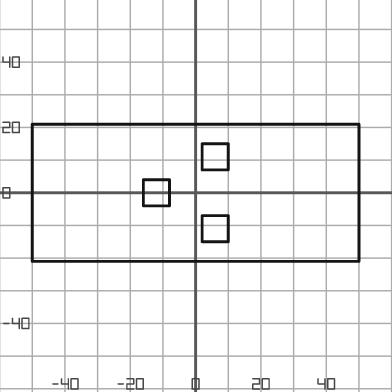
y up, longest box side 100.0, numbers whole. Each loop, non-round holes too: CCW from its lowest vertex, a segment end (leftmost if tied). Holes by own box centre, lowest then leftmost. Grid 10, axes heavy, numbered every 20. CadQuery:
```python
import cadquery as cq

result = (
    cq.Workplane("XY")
    .moveTo(-50.0, -21.0)
    .lineTo(50.0, -21.0)
    .lineTo(50.0, 21.0)
    .lineTo(-50.0, 21.0)
    .close()
    .moveTo(2.0, -15.0)
    .lineTo(10.0, -15.0)
    .lineTo(10.0, -7.0)
    .lineTo(2.0, -7.0)
    .close()
    .moveTo(-16.0, -4.0)
    .lineTo(-8.0, -4.0)
    .lineTo(-8.0, 4.0)
    .lineTo(-16.0, 4.0)
    .close()
    .moveTo(2.0, 7.0)
    .lineTo(10.0, 7.0)
    .lineTo(10.0, 15.0)
    .lineTo(2.0, 15.0)
    .close()
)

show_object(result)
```